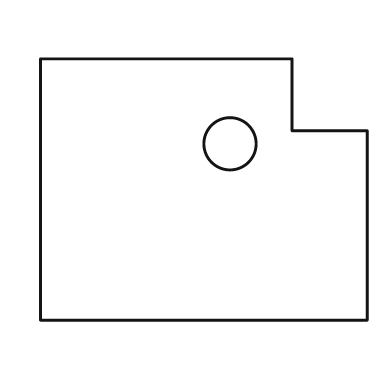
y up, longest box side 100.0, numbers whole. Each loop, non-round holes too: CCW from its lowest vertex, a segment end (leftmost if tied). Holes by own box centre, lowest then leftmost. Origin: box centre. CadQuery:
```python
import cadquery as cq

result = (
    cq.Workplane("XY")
    .moveTo(-50.0, -40.0)
    .lineTo(50.0, -40.0)
    .lineTo(50.0, 18.0)
    .lineTo(27.0, 18.0)
    .lineTo(27.0, 40.0)
    .lineTo(-50.0, 40.0)
    .close()
    .moveTo(8.0, 14.0)
    .circle(8.0)
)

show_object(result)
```